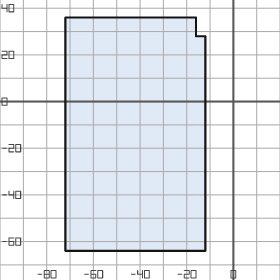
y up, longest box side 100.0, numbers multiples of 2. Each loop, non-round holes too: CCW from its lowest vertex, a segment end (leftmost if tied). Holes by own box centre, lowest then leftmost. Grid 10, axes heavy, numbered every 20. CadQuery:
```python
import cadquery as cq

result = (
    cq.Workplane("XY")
    .moveTo(-72.0, -64.0)
    .lineTo(-12.0, -64.0)
    .lineTo(-12.0, 28.0)
    .lineTo(-16.0, 28.0)
    .lineTo(-16.0, 36.0)
    .lineTo(-72.0, 36.0)
    .close()
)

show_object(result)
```